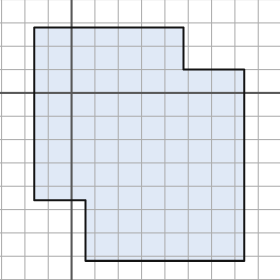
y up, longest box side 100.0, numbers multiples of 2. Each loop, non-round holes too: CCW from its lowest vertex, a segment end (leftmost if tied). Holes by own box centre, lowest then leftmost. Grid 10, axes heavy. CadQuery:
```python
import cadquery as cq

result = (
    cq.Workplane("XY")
    .moveTo(6.0, -72.0)
    .lineTo(74.0, -72.0)
    .lineTo(74.0, 10.0)
    .lineTo(48.0, 10.0)
    .lineTo(48.0, 28.0)
    .lineTo(-16.0, 28.0)
    .lineTo(-16.0, -46.0)
    .lineTo(6.0, -46.0)
    .close()
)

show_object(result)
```